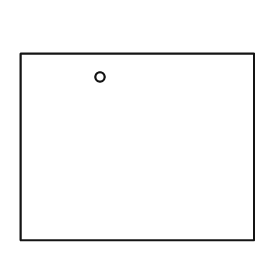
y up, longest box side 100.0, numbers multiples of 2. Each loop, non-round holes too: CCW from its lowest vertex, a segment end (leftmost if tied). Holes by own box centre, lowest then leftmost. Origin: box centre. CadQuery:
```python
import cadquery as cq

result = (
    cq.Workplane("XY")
    .moveTo(-50.0, -40.0)
    .lineTo(50.0, -40.0)
    .lineTo(50.0, 40.0)
    .lineTo(-50.0, 40.0)
    .close()
    .moveTo(-16.0, 30.0)
    .circle(2.0)
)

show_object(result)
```